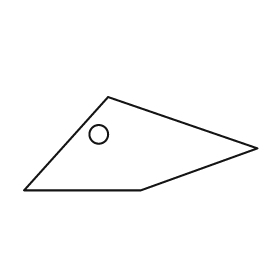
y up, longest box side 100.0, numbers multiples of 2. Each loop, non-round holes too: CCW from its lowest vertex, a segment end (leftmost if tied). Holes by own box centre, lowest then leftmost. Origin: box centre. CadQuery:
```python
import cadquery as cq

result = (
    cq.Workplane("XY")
    .moveTo(-50.0, -20.0)
    .lineTo(0.0, -20.0)
    .lineTo(50.0, -2.0)
    .lineTo(-14.0, 20.0)
    .close()
    .moveTo(-18.0, 4.0)
    .circle(4.0)
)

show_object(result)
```